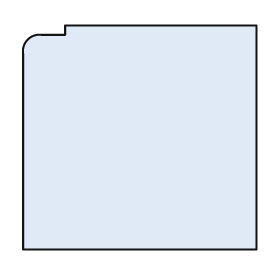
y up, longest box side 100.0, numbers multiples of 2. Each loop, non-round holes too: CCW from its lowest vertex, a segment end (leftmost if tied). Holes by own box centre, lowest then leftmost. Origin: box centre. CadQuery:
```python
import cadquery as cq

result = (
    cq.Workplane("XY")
    .moveTo(-50.0, -48.0)
    .lineTo(50.0, -48.0)
    .lineTo(50.0, 48.0)
    .lineTo(-32.0, 48.0)
    .lineTo(-32.0, 44.0)
    .lineTo(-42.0, 44.0)
    .threePointArc((-48.0, 42.0), (-50.0, 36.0))
    .close()
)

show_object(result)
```